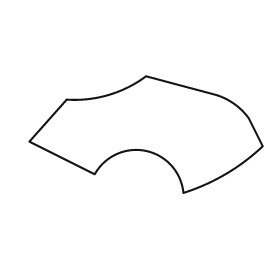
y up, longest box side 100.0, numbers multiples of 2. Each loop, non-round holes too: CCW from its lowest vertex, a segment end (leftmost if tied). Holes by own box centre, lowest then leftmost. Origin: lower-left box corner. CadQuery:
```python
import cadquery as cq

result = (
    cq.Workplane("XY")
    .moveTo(66.0, 0.0)
    .threePointArc((84.0, 8.0), (100.0, 20.0))
    .lineTo(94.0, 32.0)
    .threePointArc((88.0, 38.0), (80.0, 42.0))
    .lineTo(50.0, 50.0)
    .threePointArc((34.0, 42.0), (16.0, 40.0))
    .lineTo(0.0, 22.0)
    .lineTo(28.0, 8.0)
    .threePointArc((50.0, 18.0), (66.0, 0.0))
    .close()
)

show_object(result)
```